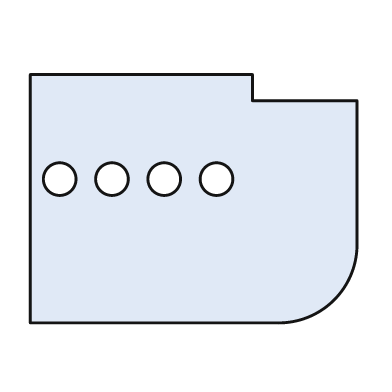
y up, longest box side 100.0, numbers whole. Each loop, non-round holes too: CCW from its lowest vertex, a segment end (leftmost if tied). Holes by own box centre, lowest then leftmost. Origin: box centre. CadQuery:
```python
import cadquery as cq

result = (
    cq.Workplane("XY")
    .moveTo(-50.0, -38.0)
    .lineTo(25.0, -38.0)
    .threePointArc((43.0, -31.0), (50.0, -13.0))
    .lineTo(50.0, 30.0)
    .lineTo(18.0, 30.0)
    .lineTo(18.0, 38.0)
    .lineTo(-50.0, 38.0)
    .close()
    .moveTo(-41.0, 6.0)
    .circle(5.0)
    .moveTo(-25.0, 6.0)
    .circle(5.0)
    .moveTo(-9.0, 6.0)
    .circle(5.0)
    .moveTo(7.0, 6.0)
    .circle(5.0)
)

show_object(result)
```